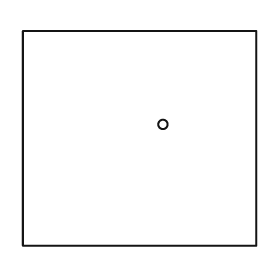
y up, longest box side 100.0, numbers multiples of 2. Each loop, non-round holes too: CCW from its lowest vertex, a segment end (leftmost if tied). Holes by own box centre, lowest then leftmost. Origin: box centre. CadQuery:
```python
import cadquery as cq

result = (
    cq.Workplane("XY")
    .moveTo(-50.0, -46.0)
    .lineTo(50.0, -46.0)
    .lineTo(50.0, 46.0)
    .lineTo(-50.0, 46.0)
    .close()
    .moveTo(10.0, 6.0)
    .circle(2.0)
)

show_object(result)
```